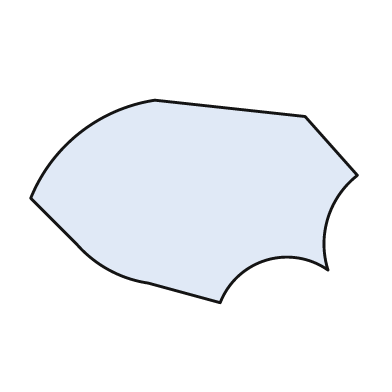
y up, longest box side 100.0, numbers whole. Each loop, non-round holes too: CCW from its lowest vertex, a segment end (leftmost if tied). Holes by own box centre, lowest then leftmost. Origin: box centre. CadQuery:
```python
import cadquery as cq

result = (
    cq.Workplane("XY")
    .moveTo(8.0, -31.0)
    .threePointArc((22.0, -18.0), (41.0, -21.0))
    .threePointArc((41.0, -5.0), (50.0, 8.0))
    .lineTo(34.0, 26.0)
    .lineTo(-12.0, 31.0)
    .threePointArc((-35.0, 21.0), (-50.0, 1.0))
    .lineTo(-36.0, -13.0)
    .threePointArc((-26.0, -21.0), (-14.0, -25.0))
    .close()
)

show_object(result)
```